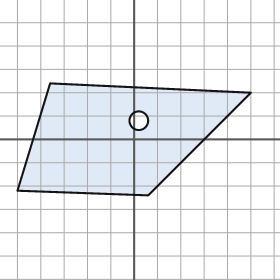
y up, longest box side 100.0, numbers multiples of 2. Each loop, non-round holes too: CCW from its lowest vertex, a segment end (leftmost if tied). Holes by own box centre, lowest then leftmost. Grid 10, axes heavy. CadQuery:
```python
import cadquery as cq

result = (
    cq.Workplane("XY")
    .moveTo(6.0, -24.0)
    .lineTo(50.0, 20.0)
    .lineTo(-36.0, 24.0)
    .lineTo(-50.0, -22.0)
    .close()
    .moveTo(2.0, 8.0)
    .circle(4.0)
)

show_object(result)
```